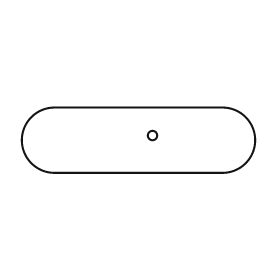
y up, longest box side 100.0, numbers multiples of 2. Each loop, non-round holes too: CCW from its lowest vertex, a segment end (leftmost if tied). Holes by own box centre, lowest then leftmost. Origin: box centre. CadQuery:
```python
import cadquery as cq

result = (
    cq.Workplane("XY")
    .moveTo(-36.0, -14.0)
    .lineTo(36.0, -14.0)
    .threePointArc((50.0, 0.0), (36.0, 14.0))
    .lineTo(-36.0, 14.0)
    .threePointArc((-50.0, 0.0), (-36.0, -14.0))
    .close()
    .moveTo(6.0, 2.0)
    .circle(2.0)
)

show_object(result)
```